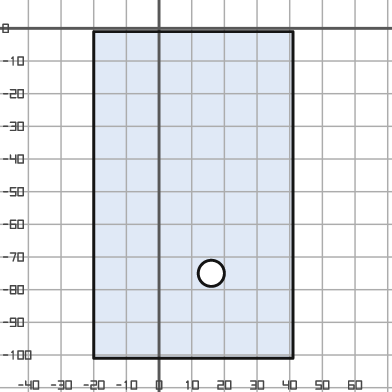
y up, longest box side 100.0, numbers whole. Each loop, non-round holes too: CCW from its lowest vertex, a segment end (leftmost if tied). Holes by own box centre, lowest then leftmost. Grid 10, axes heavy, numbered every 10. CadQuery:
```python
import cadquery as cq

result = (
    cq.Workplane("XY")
    .moveTo(-20.0, -101.0)
    .lineTo(41.0, -101.0)
    .lineTo(41.0, -1.0)
    .lineTo(-20.0, -1.0)
    .close()
    .moveTo(16.0, -75.0)
    .circle(4.0)
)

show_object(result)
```